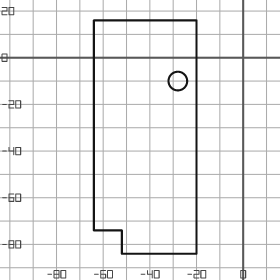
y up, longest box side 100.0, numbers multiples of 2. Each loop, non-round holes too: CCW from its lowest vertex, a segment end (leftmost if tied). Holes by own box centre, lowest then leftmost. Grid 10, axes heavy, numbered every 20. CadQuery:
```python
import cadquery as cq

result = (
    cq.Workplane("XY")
    .moveTo(-52.0, -84.0)
    .lineTo(-20.0, -84.0)
    .lineTo(-20.0, 16.0)
    .lineTo(-64.0, 16.0)
    .lineTo(-64.0, -74.0)
    .lineTo(-52.0, -74.0)
    .close()
    .moveTo(-28.0, -10.0)
    .circle(4.0)
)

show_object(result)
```